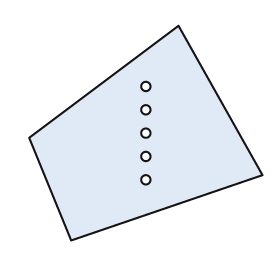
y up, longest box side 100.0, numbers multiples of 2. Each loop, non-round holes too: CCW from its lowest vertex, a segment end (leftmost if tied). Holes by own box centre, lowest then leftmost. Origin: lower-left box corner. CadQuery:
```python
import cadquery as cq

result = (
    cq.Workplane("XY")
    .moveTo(18.0, 0.0)
    .lineTo(100.0, 28.0)
    .lineTo(64.0, 92.0)
    .lineTo(0.0, 44.0)
    .close()
    .moveTo(50.0, 26.0)
    .circle(2.0)
    .moveTo(50.0, 36.0)
    .circle(2.0)
    .moveTo(50.0, 46.0)
    .circle(2.0)
    .moveTo(50.0, 56.0)
    .circle(2.0)
    .moveTo(50.0, 66.0)
    .circle(2.0)
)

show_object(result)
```